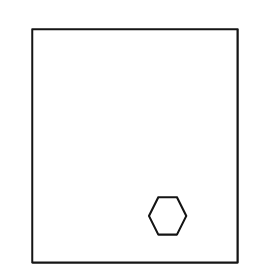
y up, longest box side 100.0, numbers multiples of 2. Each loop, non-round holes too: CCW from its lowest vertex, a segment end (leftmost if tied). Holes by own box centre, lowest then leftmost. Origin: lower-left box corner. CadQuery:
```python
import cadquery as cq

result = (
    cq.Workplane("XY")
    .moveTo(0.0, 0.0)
    .lineTo(88.0, 0.0)
    .lineTo(88.0, 100.0)
    .lineTo(0.0, 100.0)
    .close()
    .moveTo(54.0, 12.0)
    .lineTo(62.0, 12.0)
    .lineTo(66.0, 20.0)
    .lineTo(62.0, 28.0)
    .lineTo(54.0, 28.0)
    .lineTo(50.0, 20.0)
    .close()
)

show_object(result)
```